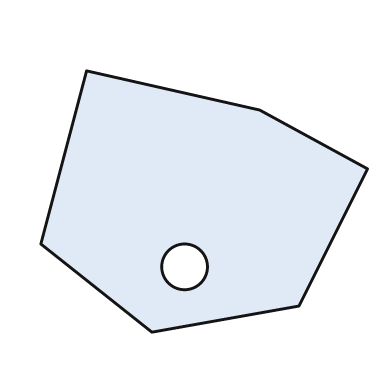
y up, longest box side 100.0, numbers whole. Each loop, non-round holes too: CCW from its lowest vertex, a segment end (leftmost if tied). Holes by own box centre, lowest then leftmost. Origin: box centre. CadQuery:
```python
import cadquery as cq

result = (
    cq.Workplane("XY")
    .moveTo(-16.0, -40.0)
    .lineTo(29.0, -32.0)
    .lineTo(50.0, 10.0)
    .lineTo(17.0, 28.0)
    .lineTo(-36.0, 40.0)
    .lineTo(-50.0, -13.0)
    .close()
    .moveTo(-6.0, -20.0)
    .circle(7.0)
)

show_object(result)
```